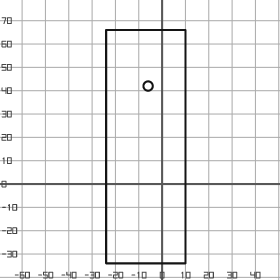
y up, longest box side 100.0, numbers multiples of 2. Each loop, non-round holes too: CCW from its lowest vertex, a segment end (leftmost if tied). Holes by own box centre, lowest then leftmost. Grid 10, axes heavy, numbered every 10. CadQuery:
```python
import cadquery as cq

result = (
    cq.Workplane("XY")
    .moveTo(-24.0, -34.0)
    .lineTo(10.0, -34.0)
    .lineTo(10.0, 66.0)
    .lineTo(-24.0, 66.0)
    .close()
    .moveTo(-6.0, 42.0)
    .circle(2.0)
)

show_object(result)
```